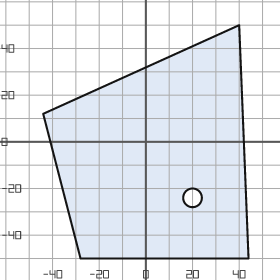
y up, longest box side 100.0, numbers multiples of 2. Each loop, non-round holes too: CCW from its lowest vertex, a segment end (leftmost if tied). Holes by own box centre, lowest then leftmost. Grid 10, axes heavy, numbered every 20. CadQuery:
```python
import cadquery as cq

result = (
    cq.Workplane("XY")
    .moveTo(-28.0, -50.0)
    .lineTo(44.0, -50.0)
    .lineTo(40.0, 50.0)
    .lineTo(-44.0, 12.0)
    .close()
    .moveTo(20.0, -24.0)
    .circle(4.0)
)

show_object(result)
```